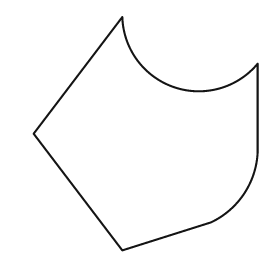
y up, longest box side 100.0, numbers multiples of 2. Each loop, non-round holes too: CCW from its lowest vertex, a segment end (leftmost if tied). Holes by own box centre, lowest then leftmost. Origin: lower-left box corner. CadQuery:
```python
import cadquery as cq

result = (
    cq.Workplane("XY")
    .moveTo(38.0, 0.0)
    .lineTo(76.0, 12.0)
    .threePointArc((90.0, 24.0), (96.0, 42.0))
    .lineTo(96.0, 80.0)
    .threePointArc((60.0, 70.0), (38.0, 100.0))
    .lineTo(0.0, 50.0)
    .close()
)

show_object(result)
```